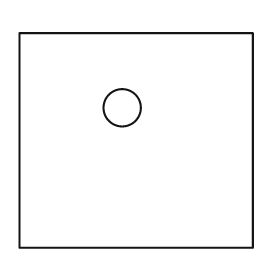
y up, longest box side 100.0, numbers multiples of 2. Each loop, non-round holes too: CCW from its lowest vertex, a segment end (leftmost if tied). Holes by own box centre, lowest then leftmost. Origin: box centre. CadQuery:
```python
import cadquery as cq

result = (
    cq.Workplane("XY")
    .moveTo(-50.0, -46.0)
    .lineTo(50.0, -46.0)
    .lineTo(50.0, 46.0)
    .lineTo(-50.0, 46.0)
    .close()
    .moveTo(-6.0, 14.0)
    .circle(8.0)
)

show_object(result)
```